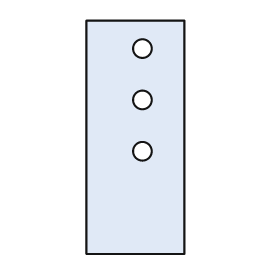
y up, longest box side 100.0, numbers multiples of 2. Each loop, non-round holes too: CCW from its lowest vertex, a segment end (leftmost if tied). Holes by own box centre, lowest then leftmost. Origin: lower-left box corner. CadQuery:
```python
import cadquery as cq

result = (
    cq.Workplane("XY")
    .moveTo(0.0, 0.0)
    .lineTo(42.0, 0.0)
    .lineTo(42.0, 100.0)
    .lineTo(0.0, 100.0)
    .close()
    .moveTo(24.0, 44.0)
    .circle(4.0)
    .moveTo(24.0, 66.0)
    .circle(4.0)
    .moveTo(24.0, 88.0)
    .circle(4.0)
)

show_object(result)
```